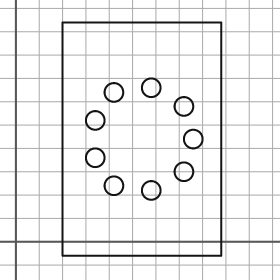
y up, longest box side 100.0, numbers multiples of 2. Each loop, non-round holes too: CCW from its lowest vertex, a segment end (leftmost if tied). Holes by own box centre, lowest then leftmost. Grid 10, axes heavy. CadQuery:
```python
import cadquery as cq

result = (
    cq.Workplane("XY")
    .moveTo(20.0, -6.0)
    .lineTo(88.0, -6.0)
    .lineTo(88.0, 94.0)
    .lineTo(20.0, 94.0)
    .close()
    .moveTo(58.0, 22.0)
    .circle(4.0)
    .moveTo(42.0, 24.0)
    .circle(4.0)
    .moveTo(72.0, 30.0)
    .circle(4.0)
    .moveTo(34.0, 36.0)
    .circle(4.0)
    .moveTo(76.0, 44.0)
    .circle(4.0)
    .moveTo(34.0, 52.0)
    .circle(4.0)
    .moveTo(72.0, 58.0)
    .circle(4.0)
    .moveTo(42.0, 64.0)
    .circle(4.0)
    .moveTo(58.0, 66.0)
    .circle(4.0)
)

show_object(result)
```